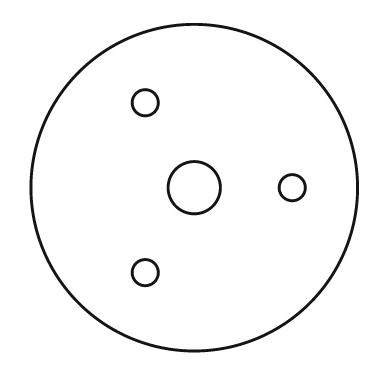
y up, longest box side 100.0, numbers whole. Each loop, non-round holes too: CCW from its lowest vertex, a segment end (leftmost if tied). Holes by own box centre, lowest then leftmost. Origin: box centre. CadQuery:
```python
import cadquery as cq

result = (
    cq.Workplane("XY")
    .moveTo(0.0, 0.0)
    .circle(50.0)
    .moveTo(-15.0, -26.0)
    .circle(4.0)
    .moveTo(0.0, 0.0)
    .circle(8.0)
    .moveTo(30.0, 0.0)
    .circle(4.0)
    .moveTo(-15.0, 26.0)
    .circle(4.0)
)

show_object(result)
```